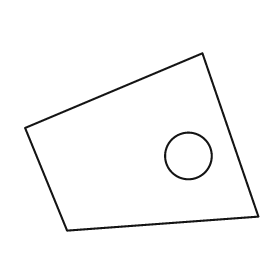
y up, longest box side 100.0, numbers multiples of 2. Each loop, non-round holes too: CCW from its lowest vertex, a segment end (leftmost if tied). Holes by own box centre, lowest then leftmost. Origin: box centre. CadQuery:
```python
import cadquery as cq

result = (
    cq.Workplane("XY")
    .moveTo(-32.0, -38.0)
    .lineTo(50.0, -32.0)
    .lineTo(26.0, 38.0)
    .lineTo(-50.0, 6.0)
    .close()
    .moveTo(20.0, -6.0)
    .circle(10.0)
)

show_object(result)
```